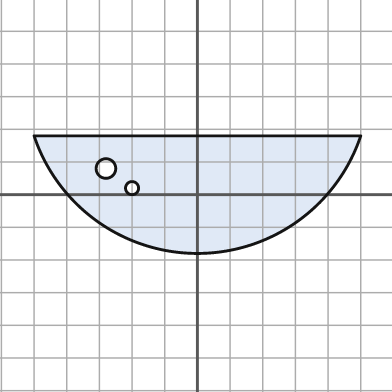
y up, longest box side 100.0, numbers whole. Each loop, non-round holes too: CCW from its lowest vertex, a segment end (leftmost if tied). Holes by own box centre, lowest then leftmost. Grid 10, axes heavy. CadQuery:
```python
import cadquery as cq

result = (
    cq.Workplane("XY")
    .moveTo(-50.0, 18.0)
    .threePointArc((0.0, -18.0), (50.0, 18.0))
    .close()
    .moveTo(-20.0, 2.0)
    .circle(2.0)
    .moveTo(-28.0, 8.0)
    .circle(3.0)
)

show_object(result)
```